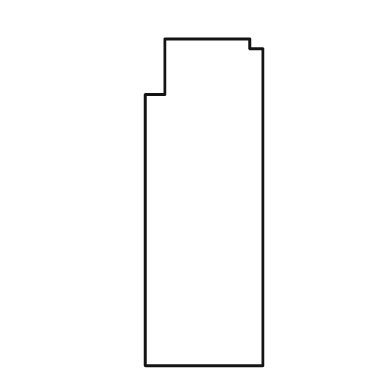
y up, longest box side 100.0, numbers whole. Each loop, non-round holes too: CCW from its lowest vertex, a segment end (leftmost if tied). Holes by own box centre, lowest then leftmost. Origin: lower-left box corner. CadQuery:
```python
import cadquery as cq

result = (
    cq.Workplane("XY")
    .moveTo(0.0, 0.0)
    .lineTo(36.0, 0.0)
    .lineTo(36.0, 97.0)
    .lineTo(32.0, 97.0)
    .lineTo(32.0, 100.0)
    .lineTo(6.0, 100.0)
    .lineTo(6.0, 83.0)
    .lineTo(0.0, 83.0)
    .close()
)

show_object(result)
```